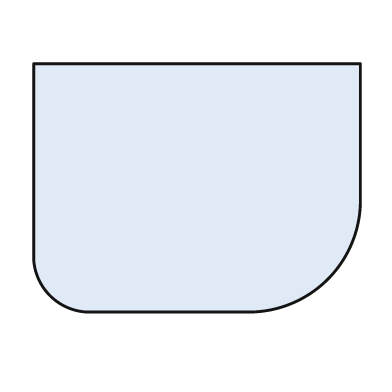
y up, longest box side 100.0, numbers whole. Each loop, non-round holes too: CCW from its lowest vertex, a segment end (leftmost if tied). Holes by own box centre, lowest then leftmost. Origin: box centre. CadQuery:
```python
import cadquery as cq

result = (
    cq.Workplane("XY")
    .moveTo(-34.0, -38.0)
    .lineTo(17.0, -38.0)
    .threePointArc((40.0, -28.0), (50.0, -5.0))
    .lineTo(50.0, 38.0)
    .lineTo(-50.0, 38.0)
    .lineTo(-50.0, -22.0)
    .threePointArc((-45.0, -33.0), (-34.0, -38.0))
    .close()
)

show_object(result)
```